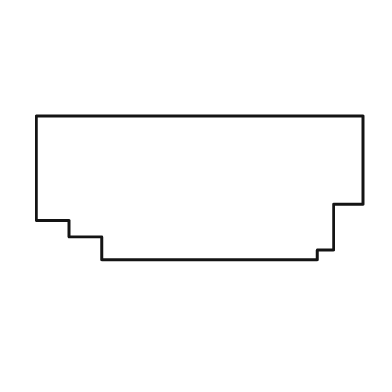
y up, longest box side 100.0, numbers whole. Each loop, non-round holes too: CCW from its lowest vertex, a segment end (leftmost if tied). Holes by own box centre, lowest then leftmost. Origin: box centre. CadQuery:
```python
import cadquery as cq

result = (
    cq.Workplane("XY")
    .moveTo(-30.0, -22.0)
    .lineTo(36.0, -22.0)
    .lineTo(36.0, -19.0)
    .lineTo(41.0, -19.0)
    .lineTo(41.0, -5.0)
    .lineTo(50.0, -5.0)
    .lineTo(50.0, 22.0)
    .lineTo(-50.0, 22.0)
    .lineTo(-50.0, -10.0)
    .lineTo(-40.0, -10.0)
    .lineTo(-40.0, -15.0)
    .lineTo(-30.0, -15.0)
    .close()
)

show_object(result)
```